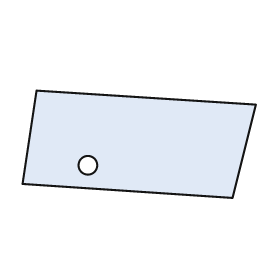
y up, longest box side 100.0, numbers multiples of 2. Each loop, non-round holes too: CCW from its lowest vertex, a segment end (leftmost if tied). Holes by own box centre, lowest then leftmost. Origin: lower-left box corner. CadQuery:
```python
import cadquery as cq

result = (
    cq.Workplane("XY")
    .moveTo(90.0, 0.0)
    .lineTo(100.0, 40.0)
    .lineTo(6.0, 46.0)
    .lineTo(0.0, 6.0)
    .close()
    .moveTo(28.0, 14.0)
    .circle(4.0)
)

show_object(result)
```